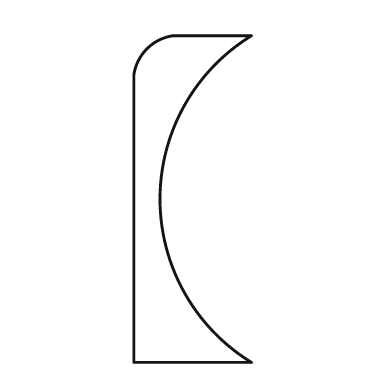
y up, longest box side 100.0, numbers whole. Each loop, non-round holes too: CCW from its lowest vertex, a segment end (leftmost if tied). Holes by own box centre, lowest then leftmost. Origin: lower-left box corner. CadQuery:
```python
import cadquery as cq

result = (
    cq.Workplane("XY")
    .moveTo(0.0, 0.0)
    .lineTo(36.0, 0.0)
    .threePointArc((8.0, 50.0), (36.0, 100.0))
    .lineTo(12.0, 100.0)
    .threePointArc((4.0, 96.0), (0.0, 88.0))
    .close()
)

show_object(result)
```